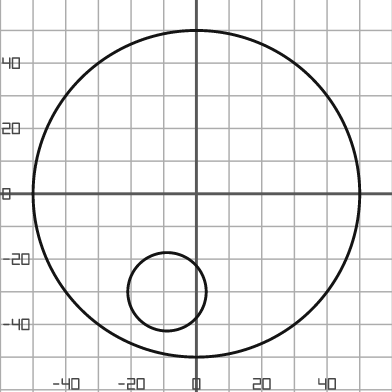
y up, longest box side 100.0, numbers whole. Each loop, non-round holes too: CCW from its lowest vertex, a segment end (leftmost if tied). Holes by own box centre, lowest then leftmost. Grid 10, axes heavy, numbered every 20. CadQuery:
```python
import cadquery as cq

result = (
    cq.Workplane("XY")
    .moveTo(0.0, 0.0)
    .circle(50.0)
    .moveTo(-9.0, -30.0)
    .circle(12.0)
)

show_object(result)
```